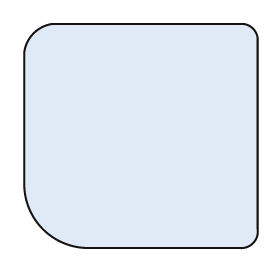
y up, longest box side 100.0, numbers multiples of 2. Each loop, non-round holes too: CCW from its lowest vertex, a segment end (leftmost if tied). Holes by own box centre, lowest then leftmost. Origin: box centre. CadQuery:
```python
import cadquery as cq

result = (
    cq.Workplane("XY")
    .moveTo(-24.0, -48.0)
    .lineTo(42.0, -48.0)
    .threePointArc((48.0, -46.0), (50.0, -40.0))
    .lineTo(50.0, 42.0)
    .threePointArc((48.0, 46.0), (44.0, 48.0))
    .lineTo(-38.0, 48.0)
    .threePointArc((-46.0, 44.0), (-50.0, 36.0))
    .lineTo(-50.0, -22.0)
    .threePointArc((-42.0, -40.0), (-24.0, -48.0))
    .close()
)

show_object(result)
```